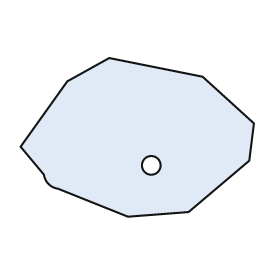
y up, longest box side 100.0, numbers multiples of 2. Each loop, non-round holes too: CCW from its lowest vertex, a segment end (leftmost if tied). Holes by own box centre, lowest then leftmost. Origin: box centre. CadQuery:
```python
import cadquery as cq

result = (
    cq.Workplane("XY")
    .moveTo(-4.0, -34.0)
    .lineTo(22.0, -32.0)
    .lineTo(48.0, -10.0)
    .lineTo(50.0, 6.0)
    .lineTo(28.0, 26.0)
    .lineTo(-12.0, 34.0)
    .lineTo(-30.0, 24.0)
    .lineTo(-50.0, -4.0)
    .lineTo(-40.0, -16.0)
    .threePointArc((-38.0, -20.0), (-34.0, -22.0))
    .close()
    .moveTo(6.0, -12.0)
    .circle(4.0)
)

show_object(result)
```